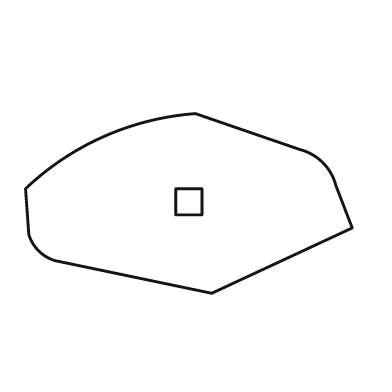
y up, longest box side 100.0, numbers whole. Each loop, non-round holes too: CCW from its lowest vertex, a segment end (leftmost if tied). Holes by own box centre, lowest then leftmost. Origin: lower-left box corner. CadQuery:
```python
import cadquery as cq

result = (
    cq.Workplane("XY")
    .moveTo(57.0, 0.0)
    .lineTo(100.0, 20.0)
    .lineTo(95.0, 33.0)
    .threePointArc((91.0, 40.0), (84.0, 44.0))
    .lineTo(52.0, 55.0)
    .threePointArc((24.0, 48.0), (0.0, 32.0))
    .lineTo(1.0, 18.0)
    .threePointArc((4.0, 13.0), (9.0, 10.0))
    .close()
    .moveTo(46.0, 24.0)
    .lineTo(54.0, 24.0)
    .lineTo(54.0, 32.0)
    .lineTo(46.0, 32.0)
    .close()
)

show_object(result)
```